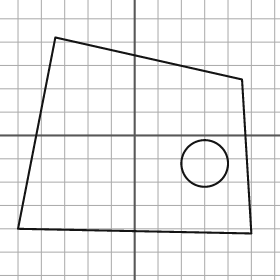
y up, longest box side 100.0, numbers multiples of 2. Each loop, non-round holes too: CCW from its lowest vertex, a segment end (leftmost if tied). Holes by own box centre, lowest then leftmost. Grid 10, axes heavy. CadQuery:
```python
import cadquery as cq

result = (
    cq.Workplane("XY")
    .moveTo(50.0, -42.0)
    .lineTo(46.0, 24.0)
    .lineTo(-34.0, 42.0)
    .lineTo(-50.0, -40.0)
    .close()
    .moveTo(30.0, -12.0)
    .circle(10.0)
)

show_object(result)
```